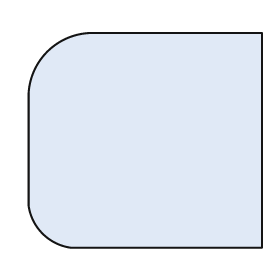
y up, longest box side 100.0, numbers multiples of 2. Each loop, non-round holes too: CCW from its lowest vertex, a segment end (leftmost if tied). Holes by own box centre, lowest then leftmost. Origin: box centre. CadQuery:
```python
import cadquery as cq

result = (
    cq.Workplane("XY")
    .moveTo(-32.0, -46.0)
    .lineTo(50.0, -46.0)
    .lineTo(50.0, 46.0)
    .lineTo(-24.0, 46.0)
    .threePointArc((-42.0, 38.0), (-50.0, 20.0))
    .lineTo(-50.0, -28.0)
    .threePointArc((-44.0, -40.0), (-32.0, -46.0))
    .close()
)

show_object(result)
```